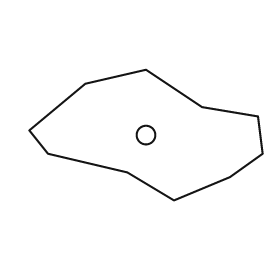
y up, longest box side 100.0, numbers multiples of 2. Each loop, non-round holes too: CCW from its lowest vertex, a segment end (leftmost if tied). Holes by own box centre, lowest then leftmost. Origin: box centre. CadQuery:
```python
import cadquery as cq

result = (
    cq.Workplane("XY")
    .moveTo(12.0, -28.0)
    .lineTo(36.0, -18.0)
    .lineTo(50.0, -8.0)
    .lineTo(48.0, 8.0)
    .lineTo(24.0, 12.0)
    .lineTo(0.0, 28.0)
    .lineTo(-26.0, 22.0)
    .lineTo(-50.0, 2.0)
    .lineTo(-42.0, -8.0)
    .lineTo(-8.0, -16.0)
    .close()
    .moveTo(0.0, 0.0)
    .circle(4.0)
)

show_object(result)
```